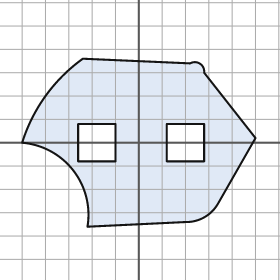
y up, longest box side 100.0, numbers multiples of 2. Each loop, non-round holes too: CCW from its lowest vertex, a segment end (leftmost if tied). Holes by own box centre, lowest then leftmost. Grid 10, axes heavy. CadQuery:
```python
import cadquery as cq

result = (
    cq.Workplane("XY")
    .moveTo(-22.0, -36.0)
    .lineTo(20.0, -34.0)
    .threePointArc((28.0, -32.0), (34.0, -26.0))
    .lineTo(50.0, 2.0)
    .lineTo(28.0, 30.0)
    .threePointArc((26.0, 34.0), (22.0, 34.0))
    .lineTo(-24.0, 36.0)
    .threePointArc((-40.0, 20.0), (-50.0, 0.0))
    .threePointArc((-28.0, -12.0), (-22.0, -36.0))
    .close()
    .moveTo(-26.0, -8.0)
    .lineTo(-10.0, -8.0)
    .lineTo(-10.0, 8.0)
    .lineTo(-26.0, 8.0)
    .close()
    .moveTo(12.0, -8.0)
    .lineTo(28.0, -8.0)
    .lineTo(28.0, 8.0)
    .lineTo(12.0, 8.0)
    .close()
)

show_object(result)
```